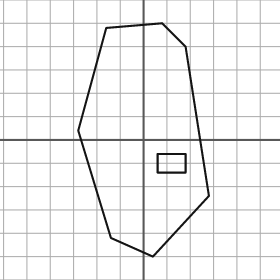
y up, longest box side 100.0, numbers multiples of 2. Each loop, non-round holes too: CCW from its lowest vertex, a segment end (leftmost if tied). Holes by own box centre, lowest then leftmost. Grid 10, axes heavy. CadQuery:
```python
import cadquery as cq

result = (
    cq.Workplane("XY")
    .moveTo(4.0, -50.0)
    .lineTo(28.0, -24.0)
    .lineTo(18.0, 40.0)
    .lineTo(8.0, 50.0)
    .lineTo(-16.0, 48.0)
    .lineTo(-28.0, 4.0)
    .lineTo(-14.0, -42.0)
    .close()
    .moveTo(6.0, -14.0)
    .lineTo(18.0, -14.0)
    .lineTo(18.0, -6.0)
    .lineTo(6.0, -6.0)
    .close()
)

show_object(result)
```